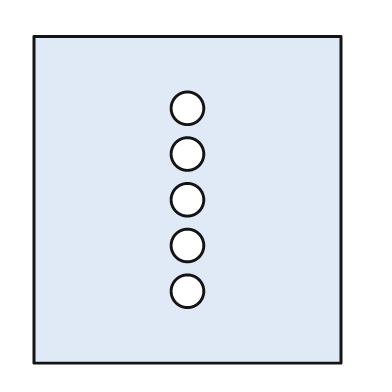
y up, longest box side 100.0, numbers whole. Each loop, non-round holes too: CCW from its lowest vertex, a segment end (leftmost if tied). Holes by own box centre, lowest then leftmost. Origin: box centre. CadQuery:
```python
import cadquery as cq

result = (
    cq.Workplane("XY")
    .moveTo(-47.0, -50.0)
    .lineTo(47.0, -50.0)
    .lineTo(47.0, 50.0)
    .lineTo(-47.0, 50.0)
    .close()
    .moveTo(0.0, -28.0)
    .circle(5.0)
    .moveTo(0.0, -14.0)
    .circle(5.0)
    .moveTo(0.0, 0.0)
    .circle(5.0)
    .moveTo(0.0, 14.0)
    .circle(5.0)
    .moveTo(0.0, 28.0)
    .circle(5.0)
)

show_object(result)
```